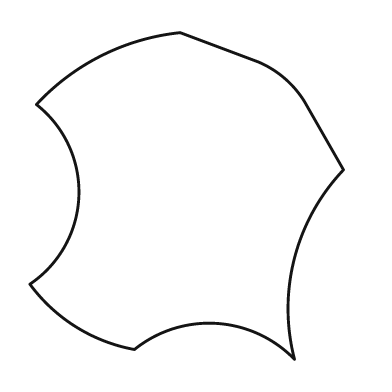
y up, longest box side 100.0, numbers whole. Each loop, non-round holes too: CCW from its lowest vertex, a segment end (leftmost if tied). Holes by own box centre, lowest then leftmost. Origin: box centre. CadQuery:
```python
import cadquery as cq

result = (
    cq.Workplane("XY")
    .moveTo(33.0, -50.0)
    .threePointArc((33.0, -19.0), (48.0, 8.0))
    .lineTo(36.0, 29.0)
    .threePointArc((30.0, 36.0), (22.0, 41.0))
    .lineTo(-2.0, 50.0)
    .threePointArc((-26.0, 43.0), (-46.0, 28.0))
    .threePointArc((-33.0, 0.0), (-48.0, -27.0))
    .threePointArc((-34.0, -40.0), (-16.0, -47.0))
    .threePointArc((9.0, -39.0), (33.0, -50.0))
    .close()
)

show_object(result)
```